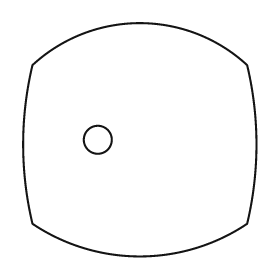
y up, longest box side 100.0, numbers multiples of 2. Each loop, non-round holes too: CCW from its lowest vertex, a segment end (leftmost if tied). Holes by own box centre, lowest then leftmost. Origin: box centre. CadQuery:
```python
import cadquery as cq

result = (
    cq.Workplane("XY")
    .moveTo(-46.0, -36.0)
    .threePointArc((0.0, -50.0), (46.0, -36.0))
    .threePointArc((50.0, -2.0), (46.0, 32.0))
    .threePointArc((0.0, 50.0), (-46.0, 32.0))
    .threePointArc((-50.0, -2.0), (-46.0, -36.0))
    .close()
    .moveTo(-18.0, 0.0)
    .circle(6.0)
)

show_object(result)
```